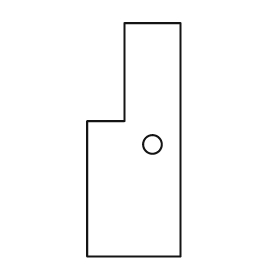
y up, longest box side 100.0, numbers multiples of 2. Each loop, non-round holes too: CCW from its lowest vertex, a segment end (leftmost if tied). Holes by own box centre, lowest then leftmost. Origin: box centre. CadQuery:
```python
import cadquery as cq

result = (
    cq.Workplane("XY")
    .moveTo(-20.0, -50.0)
    .lineTo(20.0, -50.0)
    .lineTo(20.0, 50.0)
    .lineTo(-4.0, 50.0)
    .lineTo(-4.0, 8.0)
    .lineTo(-20.0, 8.0)
    .close()
    .moveTo(8.0, -2.0)
    .circle(4.0)
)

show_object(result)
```